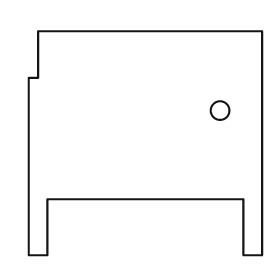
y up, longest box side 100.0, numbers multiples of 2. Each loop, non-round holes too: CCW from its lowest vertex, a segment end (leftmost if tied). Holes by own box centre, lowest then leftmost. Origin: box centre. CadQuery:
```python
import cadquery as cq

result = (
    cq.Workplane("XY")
    .moveTo(-50.0, -48.0)
    .lineTo(-42.0, -48.0)
    .lineTo(-42.0, -24.0)
    .lineTo(42.0, -24.0)
    .lineTo(42.0, -48.0)
    .lineTo(50.0, -48.0)
    .lineTo(50.0, 48.0)
    .lineTo(-46.0, 48.0)
    .lineTo(-46.0, 28.0)
    .lineTo(-50.0, 28.0)
    .close()
    .moveTo(32.0, 14.0)
    .circle(4.0)
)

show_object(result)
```